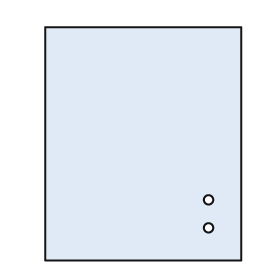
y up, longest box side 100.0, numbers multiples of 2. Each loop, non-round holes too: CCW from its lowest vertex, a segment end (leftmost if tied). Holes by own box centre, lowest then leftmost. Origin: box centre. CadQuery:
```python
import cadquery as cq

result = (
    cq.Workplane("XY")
    .moveTo(-42.0, -50.0)
    .lineTo(42.0, -50.0)
    .lineTo(42.0, 50.0)
    .lineTo(-42.0, 50.0)
    .close()
    .moveTo(28.0, -36.0)
    .circle(2.0)
    .moveTo(28.0, -24.0)
    .circle(2.0)
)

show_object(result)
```